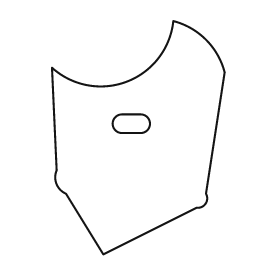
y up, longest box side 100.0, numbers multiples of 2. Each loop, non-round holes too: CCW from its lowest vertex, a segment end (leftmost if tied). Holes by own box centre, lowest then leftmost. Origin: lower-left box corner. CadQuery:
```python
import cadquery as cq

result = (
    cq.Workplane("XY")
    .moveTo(22.0, 0.0)
    .lineTo(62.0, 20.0)
    .threePointArc((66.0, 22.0), (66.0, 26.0))
    .lineTo(74.0, 78.0)
    .threePointArc((66.0, 92.0), (52.0, 100.0))
    .threePointArc((32.0, 74.0), (0.0, 80.0))
    .lineTo(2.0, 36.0)
    .threePointArc((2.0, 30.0), (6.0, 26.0))
    .close()
    .moveTo(30.0, 52.0)
    .lineTo(38.0, 52.0)
    .threePointArc((42.0, 56.0), (38.0, 60.0))
    .lineTo(30.0, 60.0)
    .threePointArc((26.0, 56.0), (30.0, 52.0))
    .close()
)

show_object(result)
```